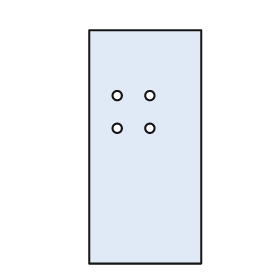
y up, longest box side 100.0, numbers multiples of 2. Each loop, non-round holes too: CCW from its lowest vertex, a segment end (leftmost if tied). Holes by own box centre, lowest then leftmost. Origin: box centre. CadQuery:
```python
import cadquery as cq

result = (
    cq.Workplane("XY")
    .moveTo(-24.0, -50.0)
    .lineTo(24.0, -50.0)
    .lineTo(24.0, 50.0)
    .lineTo(-24.0, 50.0)
    .close()
    .moveTo(-12.0, 8.0)
    .circle(2.0)
    .moveTo(2.0, 8.0)
    .circle(2.0)
    .moveTo(-12.0, 22.0)
    .circle(2.0)
    .moveTo(2.0, 22.0)
    .circle(2.0)
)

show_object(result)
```